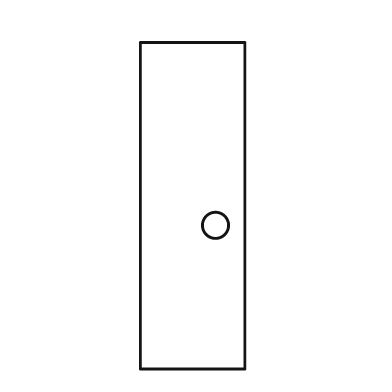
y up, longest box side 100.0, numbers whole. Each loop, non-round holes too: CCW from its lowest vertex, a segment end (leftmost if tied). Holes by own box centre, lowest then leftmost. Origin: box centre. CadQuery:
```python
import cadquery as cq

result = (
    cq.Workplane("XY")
    .moveTo(-16.0, -50.0)
    .lineTo(16.0, -50.0)
    .lineTo(16.0, 50.0)
    .lineTo(-16.0, 50.0)
    .close()
    .moveTo(7.0, -6.0)
    .circle(4.0)
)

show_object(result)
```